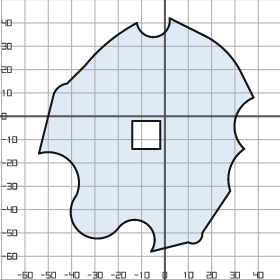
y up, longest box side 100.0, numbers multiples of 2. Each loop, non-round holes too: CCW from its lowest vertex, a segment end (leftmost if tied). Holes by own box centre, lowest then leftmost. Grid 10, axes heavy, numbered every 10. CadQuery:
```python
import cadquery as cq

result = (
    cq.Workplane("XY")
    .moveTo(-6.0, -58.0)
    .lineTo(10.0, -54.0)
    .threePointArc((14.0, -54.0), (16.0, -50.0))
    .lineTo(28.0, -32.0)
    .threePointArc((28.0, -22.0), (34.0, -14.0))
    .threePointArc((30.0, -2.0), (38.0, 8.0))
    .lineTo(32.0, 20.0)
    .threePointArc((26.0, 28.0), (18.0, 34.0))
    .lineTo(2.0, 42.0)
    .threePointArc((-4.0, 34.0), (-12.0, 40.0))
    .threePointArc((-24.0, 32.0), (-34.0, 22.0))
    .lineTo(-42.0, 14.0)
    .threePointArc((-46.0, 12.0), (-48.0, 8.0))
    .lineTo(-54.0, -16.0)
    .threePointArc((-40.0, -20.0), (-38.0, -34.0))
    .threePointArc((-36.0, -50.0), (-20.0, -48.0))
    .threePointArc((-8.0, -46.0), (-6.0, -58.0))
    .close()
    .moveTo(-14.0, -14.0)
    .lineTo(-2.0, -14.0)
    .lineTo(-2.0, -2.0)
    .lineTo(-14.0, -2.0)
    .close()
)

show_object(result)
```